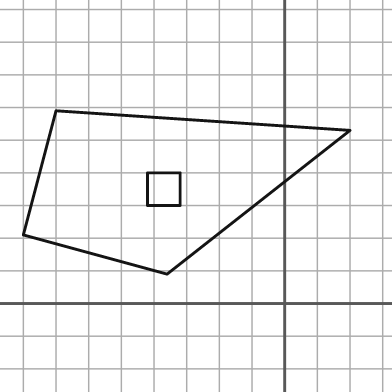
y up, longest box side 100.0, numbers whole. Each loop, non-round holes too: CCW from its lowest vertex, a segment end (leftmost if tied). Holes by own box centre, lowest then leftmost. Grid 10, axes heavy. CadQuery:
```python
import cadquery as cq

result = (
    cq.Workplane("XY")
    .moveTo(-36.0, 9.0)
    .lineTo(20.0, 53.0)
    .lineTo(-70.0, 59.0)
    .lineTo(-80.0, 21.0)
    .close()
    .moveTo(-42.0, 30.0)
    .lineTo(-32.0, 30.0)
    .lineTo(-32.0, 40.0)
    .lineTo(-42.0, 40.0)
    .close()
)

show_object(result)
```